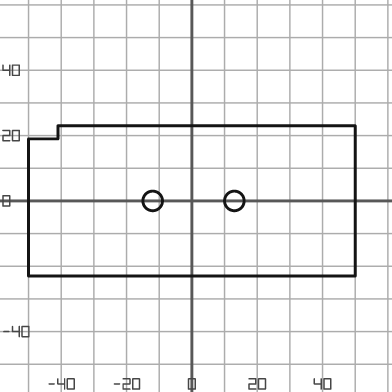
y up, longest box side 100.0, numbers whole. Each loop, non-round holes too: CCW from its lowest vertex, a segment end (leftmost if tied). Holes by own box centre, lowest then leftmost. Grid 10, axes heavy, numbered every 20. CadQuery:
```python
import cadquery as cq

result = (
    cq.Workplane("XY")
    .moveTo(-50.0, -23.0)
    .lineTo(50.0, -23.0)
    .lineTo(50.0, 23.0)
    .lineTo(-41.0, 23.0)
    .lineTo(-41.0, 19.0)
    .lineTo(-50.0, 19.0)
    .close()
    .moveTo(-12.0, 0.0)
    .circle(3.0)
    .moveTo(13.0, 0.0)
    .circle(3.0)
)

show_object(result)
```